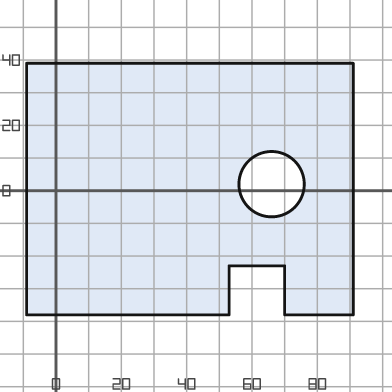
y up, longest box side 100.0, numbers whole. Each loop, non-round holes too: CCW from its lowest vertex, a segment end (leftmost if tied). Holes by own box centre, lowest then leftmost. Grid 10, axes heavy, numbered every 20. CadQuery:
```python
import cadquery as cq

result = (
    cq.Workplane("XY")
    .moveTo(-9.0, -38.0)
    .lineTo(53.0, -38.0)
    .lineTo(53.0, -23.0)
    .lineTo(70.0, -23.0)
    .lineTo(70.0, -38.0)
    .lineTo(91.0, -38.0)
    .lineTo(91.0, 39.0)
    .lineTo(-9.0, 39.0)
    .close()
    .moveTo(66.0, 2.0)
    .circle(10.0)
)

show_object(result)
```